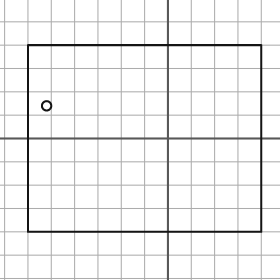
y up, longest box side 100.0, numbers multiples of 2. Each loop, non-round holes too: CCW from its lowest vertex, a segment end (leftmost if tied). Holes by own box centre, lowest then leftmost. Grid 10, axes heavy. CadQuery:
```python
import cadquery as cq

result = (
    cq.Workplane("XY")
    .moveTo(-60.0, -40.0)
    .lineTo(40.0, -40.0)
    .lineTo(40.0, 40.0)
    .lineTo(-60.0, 40.0)
    .close()
    .moveTo(-52.0, 14.0)
    .circle(2.0)
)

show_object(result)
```